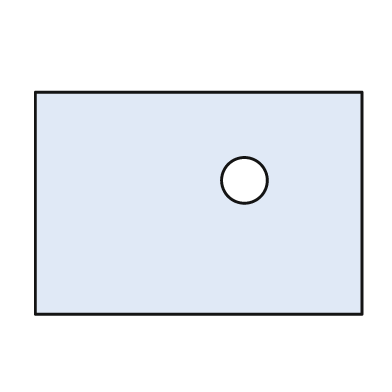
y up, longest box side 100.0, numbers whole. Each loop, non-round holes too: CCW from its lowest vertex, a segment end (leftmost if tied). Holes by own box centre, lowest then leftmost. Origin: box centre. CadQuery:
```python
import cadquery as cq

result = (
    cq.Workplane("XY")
    .moveTo(-50.0, -34.0)
    .lineTo(50.0, -34.0)
    .lineTo(50.0, 34.0)
    .lineTo(-50.0, 34.0)
    .close()
    .moveTo(14.0, 7.0)
    .circle(7.0)
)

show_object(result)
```